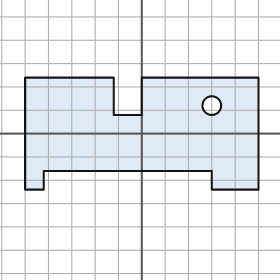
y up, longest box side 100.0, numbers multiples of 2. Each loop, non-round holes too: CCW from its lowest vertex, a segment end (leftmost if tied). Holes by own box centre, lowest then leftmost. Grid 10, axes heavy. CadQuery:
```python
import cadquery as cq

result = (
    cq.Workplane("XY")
    .moveTo(-50.0, -24.0)
    .lineTo(-42.0, -24.0)
    .lineTo(-42.0, -16.0)
    .lineTo(30.0, -16.0)
    .lineTo(30.0, -24.0)
    .lineTo(50.0, -24.0)
    .lineTo(50.0, 24.0)
    .lineTo(0.0, 24.0)
    .lineTo(0.0, 8.0)
    .lineTo(-12.0, 8.0)
    .lineTo(-12.0, 24.0)
    .lineTo(-50.0, 24.0)
    .close()
    .moveTo(30.0, 12.0)
    .circle(4.0)
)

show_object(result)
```